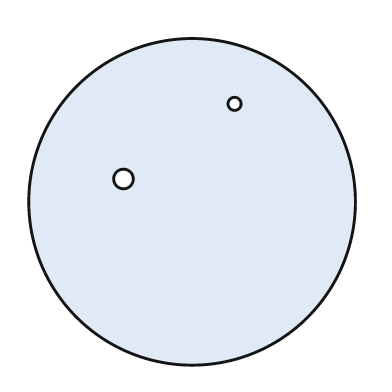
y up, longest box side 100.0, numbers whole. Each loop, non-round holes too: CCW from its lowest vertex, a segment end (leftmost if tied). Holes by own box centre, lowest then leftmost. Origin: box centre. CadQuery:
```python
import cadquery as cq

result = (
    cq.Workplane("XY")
    .moveTo(0.0, 0.0)
    .circle(50.0)
    .moveTo(-21.0, 7.0)
    .circle(3.0)
    .moveTo(13.0, 30.0)
    .circle(2.0)
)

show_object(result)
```